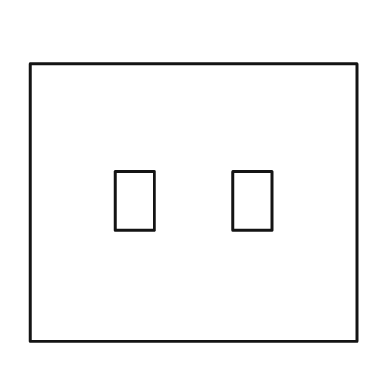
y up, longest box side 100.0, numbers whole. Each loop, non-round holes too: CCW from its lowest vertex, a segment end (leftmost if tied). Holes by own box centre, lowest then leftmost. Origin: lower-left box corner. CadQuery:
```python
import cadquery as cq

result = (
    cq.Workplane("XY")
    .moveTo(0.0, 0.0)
    .lineTo(100.0, 0.0)
    .lineTo(100.0, 85.0)
    .lineTo(0.0, 85.0)
    .close()
    .moveTo(26.0, 34.0)
    .lineTo(38.0, 34.0)
    .lineTo(38.0, 52.0)
    .lineTo(26.0, 52.0)
    .close()
    .moveTo(62.0, 34.0)
    .lineTo(74.0, 34.0)
    .lineTo(74.0, 52.0)
    .lineTo(62.0, 52.0)
    .close()
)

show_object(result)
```